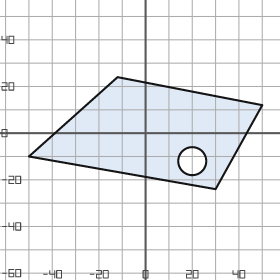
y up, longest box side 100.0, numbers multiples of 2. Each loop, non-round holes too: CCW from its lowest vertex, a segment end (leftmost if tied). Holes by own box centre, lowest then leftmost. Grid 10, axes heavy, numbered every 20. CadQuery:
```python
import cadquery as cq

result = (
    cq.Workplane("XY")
    .moveTo(30.0, -24.0)
    .lineTo(50.0, 12.0)
    .lineTo(-12.0, 24.0)
    .lineTo(-50.0, -10.0)
    .close()
    .moveTo(20.0, -12.0)
    .circle(6.0)
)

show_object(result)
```